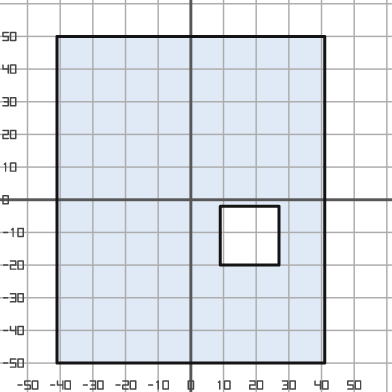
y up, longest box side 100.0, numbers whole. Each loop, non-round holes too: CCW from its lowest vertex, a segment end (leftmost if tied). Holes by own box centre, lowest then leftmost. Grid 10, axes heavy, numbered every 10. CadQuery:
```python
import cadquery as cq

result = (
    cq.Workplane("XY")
    .moveTo(-41.0, -50.0)
    .lineTo(41.0, -50.0)
    .lineTo(41.0, 50.0)
    .lineTo(-41.0, 50.0)
    .close()
    .moveTo(9.0, -20.0)
    .lineTo(27.0, -20.0)
    .lineTo(27.0, -2.0)
    .lineTo(9.0, -2.0)
    .close()
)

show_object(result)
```